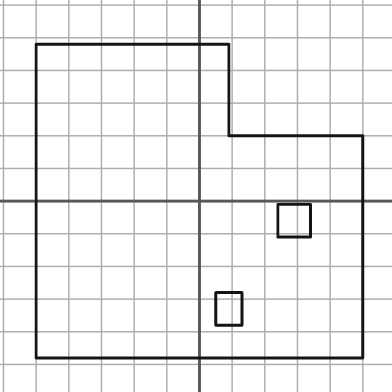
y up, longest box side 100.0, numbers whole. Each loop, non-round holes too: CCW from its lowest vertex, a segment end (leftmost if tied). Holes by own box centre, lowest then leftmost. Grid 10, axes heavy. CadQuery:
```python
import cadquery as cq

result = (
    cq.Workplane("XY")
    .moveTo(-50.0, -48.0)
    .lineTo(50.0, -48.0)
    .lineTo(50.0, 20.0)
    .lineTo(9.0, 20.0)
    .lineTo(9.0, 48.0)
    .lineTo(-50.0, 48.0)
    .close()
    .moveTo(5.0, -38.0)
    .lineTo(13.0, -38.0)
    .lineTo(13.0, -28.0)
    .lineTo(5.0, -28.0)
    .close()
    .moveTo(24.0, -11.0)
    .lineTo(34.0, -11.0)
    .lineTo(34.0, -1.0)
    .lineTo(24.0, -1.0)
    .close()
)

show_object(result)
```